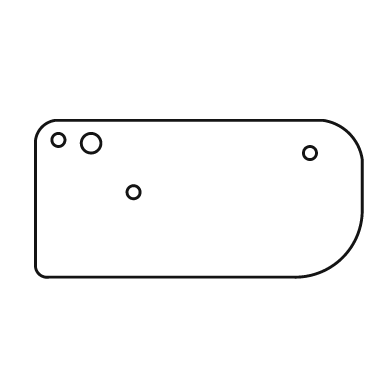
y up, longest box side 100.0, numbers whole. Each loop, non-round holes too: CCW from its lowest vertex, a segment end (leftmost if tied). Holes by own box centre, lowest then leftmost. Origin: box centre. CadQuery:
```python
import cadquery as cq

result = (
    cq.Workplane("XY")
    .moveTo(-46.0, -24.0)
    .lineTo(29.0, -24.0)
    .threePointArc((44.0, -18.0), (50.0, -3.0))
    .lineTo(50.0, 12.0)
    .threePointArc((46.0, 20.0), (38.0, 24.0))
    .lineTo(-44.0, 24.0)
    .threePointArc((-48.0, 22.0), (-50.0, 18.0))
    .lineTo(-50.0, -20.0)
    .threePointArc((-49.0, -23.0), (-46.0, -24.0))
    .close()
    .moveTo(-20.0, 2.0)
    .circle(2.0)
    .moveTo(34.0, 14.0)
    .circle(2.0)
    .moveTo(-33.0, 17.0)
    .circle(3.0)
    .moveTo(-43.0, 18.0)
    .circle(2.0)
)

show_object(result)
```